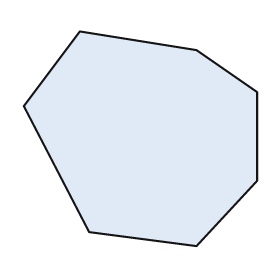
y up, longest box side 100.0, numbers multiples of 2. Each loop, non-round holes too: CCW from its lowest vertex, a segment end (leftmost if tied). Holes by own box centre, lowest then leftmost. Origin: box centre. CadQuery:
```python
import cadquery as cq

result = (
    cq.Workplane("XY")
    .moveTo(24.0, -46.0)
    .lineTo(50.0, -18.0)
    .lineTo(50.0, 20.0)
    .lineTo(24.0, 38.0)
    .lineTo(-26.0, 46.0)
    .lineTo(-50.0, 14.0)
    .lineTo(-22.0, -40.0)
    .close()
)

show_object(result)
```